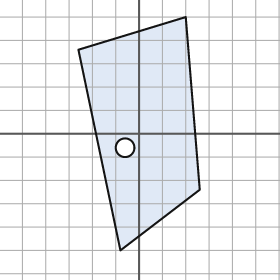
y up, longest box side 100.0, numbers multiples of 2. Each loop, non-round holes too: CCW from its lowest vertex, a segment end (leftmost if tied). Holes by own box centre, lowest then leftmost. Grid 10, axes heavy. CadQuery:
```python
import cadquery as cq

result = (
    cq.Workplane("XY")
    .moveTo(-8.0, -50.0)
    .lineTo(26.0, -24.0)
    .lineTo(20.0, 50.0)
    .lineTo(-26.0, 36.0)
    .close()
    .moveTo(-6.0, -6.0)
    .circle(4.0)
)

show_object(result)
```